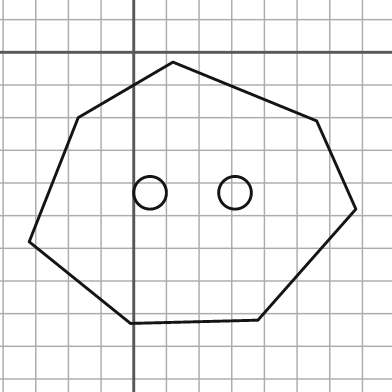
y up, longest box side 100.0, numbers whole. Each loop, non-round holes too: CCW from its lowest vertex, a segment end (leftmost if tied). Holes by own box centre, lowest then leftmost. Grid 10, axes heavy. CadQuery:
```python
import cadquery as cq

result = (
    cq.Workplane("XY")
    .moveTo(-1.0, -83.0)
    .lineTo(38.0, -82.0)
    .lineTo(68.0, -48.0)
    .lineTo(56.0, -21.0)
    .lineTo(12.0, -3.0)
    .lineTo(-17.0, -20.0)
    .lineTo(-32.0, -58.0)
    .close()
    .moveTo(5.0, -43.0)
    .circle(5.0)
    .moveTo(31.0, -43.0)
    .circle(5.0)
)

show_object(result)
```